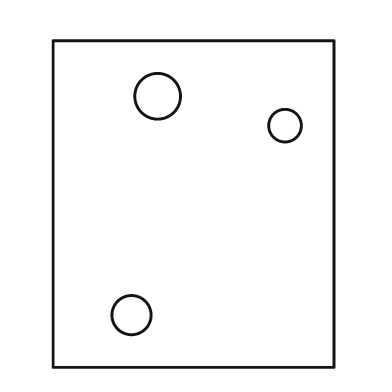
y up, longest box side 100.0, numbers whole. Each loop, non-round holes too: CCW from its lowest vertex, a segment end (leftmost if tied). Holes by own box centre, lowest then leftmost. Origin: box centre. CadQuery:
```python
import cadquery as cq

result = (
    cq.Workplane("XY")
    .moveTo(-43.0, -50.0)
    .lineTo(43.0, -50.0)
    .lineTo(43.0, 50.0)
    .lineTo(-43.0, 50.0)
    .close()
    .moveTo(-19.0, -34.0)
    .circle(6.0)
    .moveTo(28.0, 24.0)
    .circle(5.0)
    .moveTo(-11.0, 33.0)
    .circle(7.0)
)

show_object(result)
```